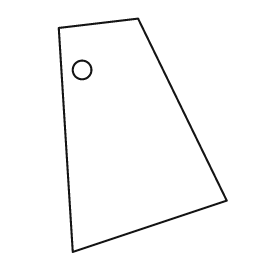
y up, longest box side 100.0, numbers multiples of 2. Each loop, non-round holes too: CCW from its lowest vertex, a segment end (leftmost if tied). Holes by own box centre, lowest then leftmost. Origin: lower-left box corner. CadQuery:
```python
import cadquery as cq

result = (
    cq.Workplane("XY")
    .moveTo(6.0, 0.0)
    .lineTo(72.0, 22.0)
    .lineTo(34.0, 100.0)
    .lineTo(0.0, 96.0)
    .close()
    .moveTo(10.0, 78.0)
    .circle(4.0)
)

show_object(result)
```